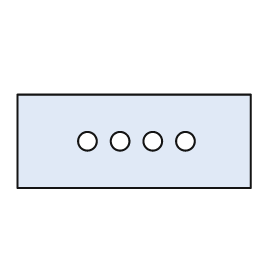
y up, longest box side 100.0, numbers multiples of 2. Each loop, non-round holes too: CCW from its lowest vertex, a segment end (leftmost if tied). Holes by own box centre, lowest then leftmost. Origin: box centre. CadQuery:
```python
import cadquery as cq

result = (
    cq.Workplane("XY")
    .moveTo(-50.0, -20.0)
    .lineTo(50.0, -20.0)
    .lineTo(50.0, 20.0)
    .lineTo(-50.0, 20.0)
    .close()
    .moveTo(-20.0, 0.0)
    .circle(4.0)
    .moveTo(-6.0, 0.0)
    .circle(4.0)
    .moveTo(8.0, 0.0)
    .circle(4.0)
    .moveTo(22.0, 0.0)
    .circle(4.0)
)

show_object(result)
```